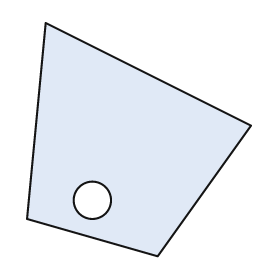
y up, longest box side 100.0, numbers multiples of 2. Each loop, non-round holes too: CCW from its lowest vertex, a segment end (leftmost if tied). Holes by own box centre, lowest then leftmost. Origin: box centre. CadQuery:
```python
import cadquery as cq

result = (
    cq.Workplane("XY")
    .moveTo(8.0, -50.0)
    .lineTo(48.0, 6.0)
    .lineTo(-40.0, 50.0)
    .lineTo(-48.0, -34.0)
    .close()
    .moveTo(-20.0, -26.0)
    .circle(8.0)
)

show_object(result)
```